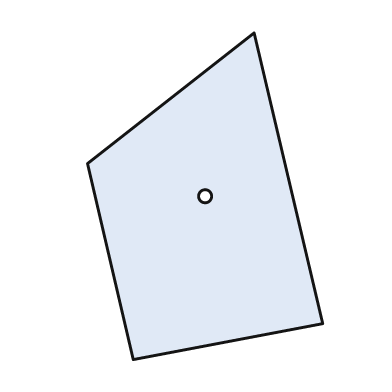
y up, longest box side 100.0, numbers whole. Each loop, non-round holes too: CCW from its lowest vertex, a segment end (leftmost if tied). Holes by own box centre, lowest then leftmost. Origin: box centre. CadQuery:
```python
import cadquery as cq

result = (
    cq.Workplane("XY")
    .moveTo(-22.0, -50.0)
    .lineTo(36.0, -39.0)
    .lineTo(15.0, 50.0)
    .lineTo(-36.0, 10.0)
    .close()
    .moveTo(0.0, 0.0)
    .circle(2.0)
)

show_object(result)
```